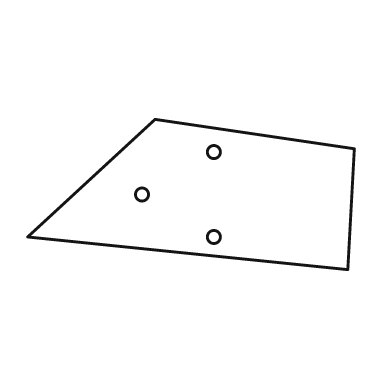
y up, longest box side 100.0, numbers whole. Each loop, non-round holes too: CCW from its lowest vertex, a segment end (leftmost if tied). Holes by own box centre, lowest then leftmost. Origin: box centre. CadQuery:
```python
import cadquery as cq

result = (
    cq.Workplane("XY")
    .moveTo(48.0, -23.0)
    .lineTo(50.0, 14.0)
    .lineTo(-11.0, 23.0)
    .lineTo(-50.0, -13.0)
    .close()
    .moveTo(7.0, -13.0)
    .circle(2.0)
    .moveTo(-15.0, 0.0)
    .circle(2.0)
    .moveTo(7.0, 13.0)
    .circle(2.0)
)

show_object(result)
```